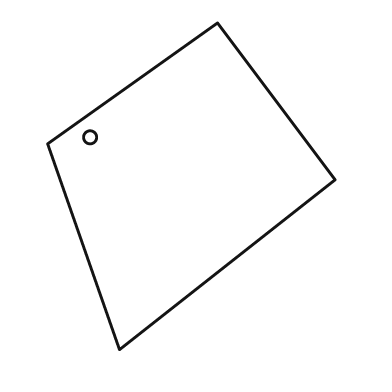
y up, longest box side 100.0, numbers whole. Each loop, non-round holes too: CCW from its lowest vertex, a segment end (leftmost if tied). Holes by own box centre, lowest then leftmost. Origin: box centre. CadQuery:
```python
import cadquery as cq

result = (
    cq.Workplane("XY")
    .moveTo(-22.0, -50.0)
    .lineTo(44.0, 2.0)
    .lineTo(8.0, 50.0)
    .lineTo(-44.0, 13.0)
    .close()
    .moveTo(-31.0, 15.0)
    .circle(2.0)
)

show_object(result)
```